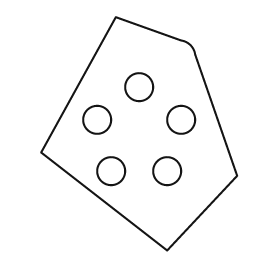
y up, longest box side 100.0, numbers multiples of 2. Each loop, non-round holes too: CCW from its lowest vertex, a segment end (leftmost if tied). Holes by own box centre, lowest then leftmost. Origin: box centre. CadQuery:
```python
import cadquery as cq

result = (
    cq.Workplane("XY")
    .moveTo(12.0, -50.0)
    .lineTo(42.0, -18.0)
    .lineTo(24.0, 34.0)
    .threePointArc((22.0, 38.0), (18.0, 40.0))
    .lineTo(-10.0, 50.0)
    .lineTo(-42.0, -8.0)
    .close()
    .moveTo(-12.0, -16.0)
    .circle(6.0)
    .moveTo(12.0, -16.0)
    .circle(6.0)
    .moveTo(-18.0, 6.0)
    .circle(6.0)
    .moveTo(18.0, 6.0)
    .circle(6.0)
    .moveTo(0.0, 20.0)
    .circle(6.0)
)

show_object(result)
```